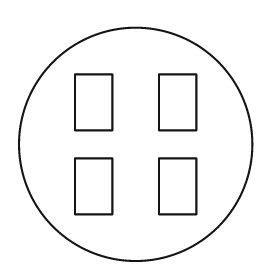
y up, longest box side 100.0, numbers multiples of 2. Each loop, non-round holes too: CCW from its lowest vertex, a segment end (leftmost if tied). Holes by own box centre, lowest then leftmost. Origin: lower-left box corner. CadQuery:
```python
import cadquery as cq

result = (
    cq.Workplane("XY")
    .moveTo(50.0, 50.0)
    .circle(50.0)
    .moveTo(24.0, 20.0)
    .lineTo(40.0, 20.0)
    .lineTo(40.0, 44.0)
    .lineTo(24.0, 44.0)
    .close()
    .moveTo(60.0, 20.0)
    .lineTo(76.0, 20.0)
    .lineTo(76.0, 44.0)
    .lineTo(60.0, 44.0)
    .close()
    .moveTo(24.0, 56.0)
    .lineTo(40.0, 56.0)
    .lineTo(40.0, 80.0)
    .lineTo(24.0, 80.0)
    .close()
    .moveTo(60.0, 56.0)
    .lineTo(76.0, 56.0)
    .lineTo(76.0, 80.0)
    .lineTo(60.0, 80.0)
    .close()
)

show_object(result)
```